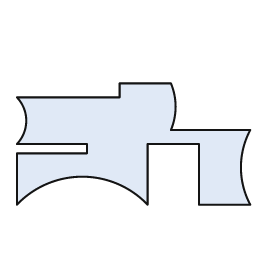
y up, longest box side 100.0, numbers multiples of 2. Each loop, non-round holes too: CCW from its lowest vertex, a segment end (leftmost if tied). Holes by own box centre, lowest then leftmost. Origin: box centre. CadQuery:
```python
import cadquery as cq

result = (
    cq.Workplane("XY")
    .moveTo(-50.0, -26.0)
    .threePointArc((-22.0, -14.0), (6.0, -26.0))
    .lineTo(6.0, 0.0)
    .lineTo(28.0, 0.0)
    .lineTo(28.0, -26.0)
    .lineTo(50.0, -26.0)
    .threePointArc((46.0, -10.0), (50.0, 6.0))
    .lineTo(16.0, 6.0)
    .threePointArc((18.0, 16.0), (16.0, 26.0))
    .lineTo(-6.0, 26.0)
    .lineTo(-6.0, 20.0)
    .lineTo(-50.0, 20.0)
    .threePointArc((-46.0, 10.0), (-50.0, 0.0))
    .lineTo(-20.0, 0.0)
    .lineTo(-20.0, -4.0)
    .lineTo(-50.0, -4.0)
    .close()
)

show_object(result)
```